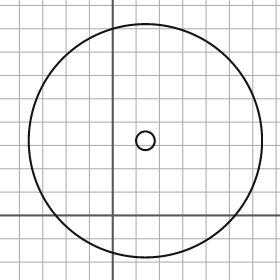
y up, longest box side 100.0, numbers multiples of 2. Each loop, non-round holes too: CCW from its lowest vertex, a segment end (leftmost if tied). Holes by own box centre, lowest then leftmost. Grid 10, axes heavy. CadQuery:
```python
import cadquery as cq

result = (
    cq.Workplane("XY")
    .moveTo(14.0, 32.0)
    .circle(50.0)
    .moveTo(14.0, 32.0)
    .circle(4.0)
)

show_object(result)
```